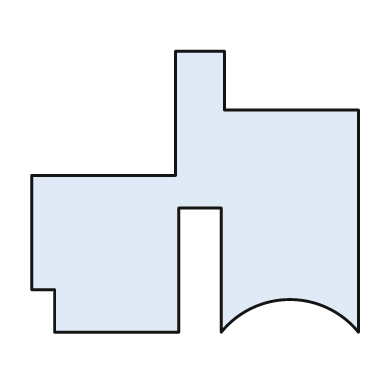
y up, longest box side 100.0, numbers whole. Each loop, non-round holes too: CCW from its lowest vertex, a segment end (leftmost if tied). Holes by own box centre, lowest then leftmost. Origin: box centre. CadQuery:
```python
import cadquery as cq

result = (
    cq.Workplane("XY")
    .moveTo(-43.0, -43.0)
    .lineTo(-5.0, -43.0)
    .lineTo(-5.0, -5.0)
    .lineTo(8.0, -5.0)
    .lineTo(8.0, -43.0)
    .threePointArc((29.0, -33.0), (50.0, -43.0))
    .lineTo(50.0, 25.0)
    .lineTo(9.0, 25.0)
    .lineTo(9.0, 43.0)
    .lineTo(-6.0, 43.0)
    .lineTo(-6.0, 5.0)
    .lineTo(-50.0, 5.0)
    .lineTo(-50.0, -30.0)
    .lineTo(-43.0, -30.0)
    .close()
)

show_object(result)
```